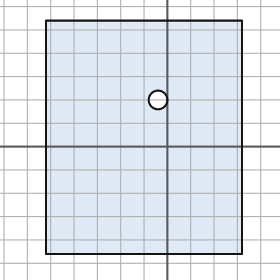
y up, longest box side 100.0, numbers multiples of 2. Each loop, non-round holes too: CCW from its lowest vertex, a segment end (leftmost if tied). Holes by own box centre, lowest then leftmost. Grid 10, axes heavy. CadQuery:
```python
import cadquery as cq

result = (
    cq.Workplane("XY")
    .moveTo(-52.0, -46.0)
    .lineTo(32.0, -46.0)
    .lineTo(32.0, 54.0)
    .lineTo(-52.0, 54.0)
    .close()
    .moveTo(-4.0, 20.0)
    .circle(4.0)
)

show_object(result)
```